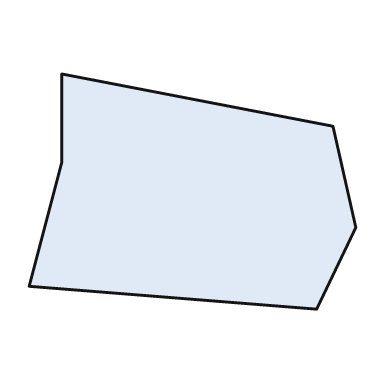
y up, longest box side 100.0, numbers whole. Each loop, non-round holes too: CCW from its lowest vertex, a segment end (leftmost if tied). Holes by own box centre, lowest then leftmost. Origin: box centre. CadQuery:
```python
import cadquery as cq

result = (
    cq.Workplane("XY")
    .moveTo(38.0, -36.0)
    .lineTo(50.0, -11.0)
    .lineTo(43.0, 20.0)
    .lineTo(-40.0, 36.0)
    .lineTo(-40.0, 9.0)
    .lineTo(-50.0, -29.0)
    .close()
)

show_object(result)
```